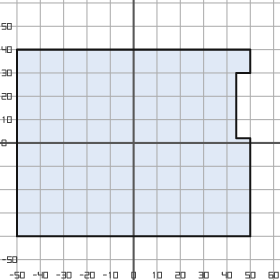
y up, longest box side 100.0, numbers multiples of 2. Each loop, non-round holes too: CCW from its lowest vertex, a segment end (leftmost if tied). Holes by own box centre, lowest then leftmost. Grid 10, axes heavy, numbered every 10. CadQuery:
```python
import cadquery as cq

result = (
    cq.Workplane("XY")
    .moveTo(-50.0, -40.0)
    .lineTo(50.0, -40.0)
    .lineTo(50.0, 2.0)
    .lineTo(44.0, 2.0)
    .lineTo(44.0, 30.0)
    .lineTo(50.0, 30.0)
    .lineTo(50.0, 40.0)
    .lineTo(-50.0, 40.0)
    .close()
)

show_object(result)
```